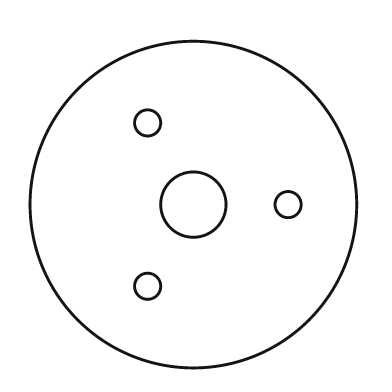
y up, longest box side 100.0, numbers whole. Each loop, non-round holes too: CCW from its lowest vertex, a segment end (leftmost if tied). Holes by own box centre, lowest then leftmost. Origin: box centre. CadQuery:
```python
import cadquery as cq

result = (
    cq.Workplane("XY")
    .moveTo(0.0, 0.0)
    .circle(50.0)
    .moveTo(-14.0, -25.0)
    .circle(4.0)
    .moveTo(0.0, 0.0)
    .circle(10.0)
    .moveTo(29.0, 0.0)
    .circle(4.0)
    .moveTo(-14.0, 25.0)
    .circle(4.0)
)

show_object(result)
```